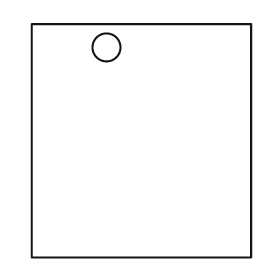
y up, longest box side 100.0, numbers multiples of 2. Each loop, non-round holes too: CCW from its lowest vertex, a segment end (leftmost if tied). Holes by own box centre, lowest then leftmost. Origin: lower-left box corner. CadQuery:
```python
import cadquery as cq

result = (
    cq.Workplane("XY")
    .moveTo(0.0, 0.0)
    .lineTo(94.0, 0.0)
    .lineTo(94.0, 100.0)
    .lineTo(0.0, 100.0)
    .close()
    .moveTo(32.0, 90.0)
    .circle(6.0)
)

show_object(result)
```